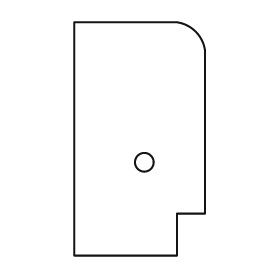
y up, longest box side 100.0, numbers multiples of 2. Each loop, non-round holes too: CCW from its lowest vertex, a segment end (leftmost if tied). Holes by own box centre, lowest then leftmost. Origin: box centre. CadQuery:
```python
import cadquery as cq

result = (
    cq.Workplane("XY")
    .moveTo(-28.0, -50.0)
    .lineTo(16.0, -50.0)
    .lineTo(16.0, -32.0)
    .lineTo(28.0, -32.0)
    .lineTo(28.0, 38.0)
    .threePointArc((24.0, 46.0), (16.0, 50.0))
    .lineTo(-28.0, 50.0)
    .close()
    .moveTo(2.0, -10.0)
    .circle(4.0)
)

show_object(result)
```